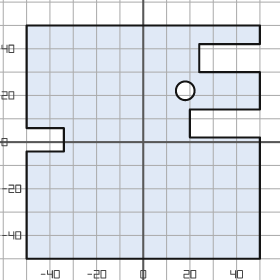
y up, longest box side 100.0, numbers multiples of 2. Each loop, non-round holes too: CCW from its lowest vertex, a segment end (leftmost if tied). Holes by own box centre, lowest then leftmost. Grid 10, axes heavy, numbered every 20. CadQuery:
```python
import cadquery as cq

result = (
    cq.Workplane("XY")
    .moveTo(-50.0, -50.0)
    .lineTo(50.0, -50.0)
    .lineTo(50.0, 2.0)
    .lineTo(20.0, 2.0)
    .lineTo(20.0, 14.0)
    .lineTo(50.0, 14.0)
    .lineTo(50.0, 30.0)
    .lineTo(24.0, 30.0)
    .lineTo(24.0, 42.0)
    .lineTo(50.0, 42.0)
    .lineTo(50.0, 50.0)
    .lineTo(-50.0, 50.0)
    .lineTo(-50.0, 6.0)
    .lineTo(-34.0, 6.0)
    .lineTo(-34.0, -4.0)
    .lineTo(-50.0, -4.0)
    .close()
    .moveTo(18.0, 22.0)
    .circle(4.0)
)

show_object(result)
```